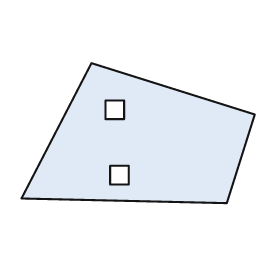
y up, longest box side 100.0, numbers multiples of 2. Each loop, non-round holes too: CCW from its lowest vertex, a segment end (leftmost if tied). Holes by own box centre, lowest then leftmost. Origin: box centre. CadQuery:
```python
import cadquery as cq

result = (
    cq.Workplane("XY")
    .moveTo(38.0, -30.0)
    .lineTo(50.0, 8.0)
    .lineTo(-20.0, 30.0)
    .lineTo(-50.0, -28.0)
    .close()
    .moveTo(-12.0, -22.0)
    .lineTo(-4.0, -22.0)
    .lineTo(-4.0, -14.0)
    .lineTo(-12.0, -14.0)
    .close()
    .moveTo(-14.0, 6.0)
    .lineTo(-6.0, 6.0)
    .lineTo(-6.0, 14.0)
    .lineTo(-14.0, 14.0)
    .close()
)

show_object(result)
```